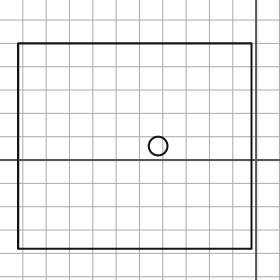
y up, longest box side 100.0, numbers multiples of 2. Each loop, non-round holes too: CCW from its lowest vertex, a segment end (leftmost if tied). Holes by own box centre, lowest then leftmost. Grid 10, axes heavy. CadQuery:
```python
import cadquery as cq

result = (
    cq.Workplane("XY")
    .moveTo(-102.0, -38.0)
    .lineTo(-2.0, -38.0)
    .lineTo(-2.0, 50.0)
    .lineTo(-102.0, 50.0)
    .close()
    .moveTo(-42.0, 6.0)
    .circle(4.0)
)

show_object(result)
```